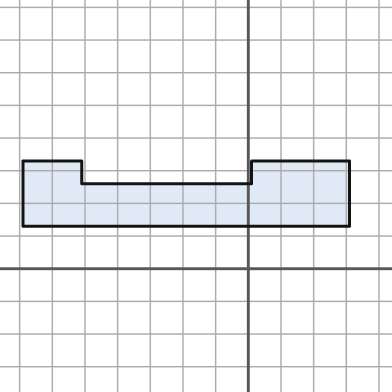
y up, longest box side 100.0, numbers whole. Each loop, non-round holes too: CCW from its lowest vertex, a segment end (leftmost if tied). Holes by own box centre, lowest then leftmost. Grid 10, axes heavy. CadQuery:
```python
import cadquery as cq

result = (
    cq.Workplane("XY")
    .moveTo(-69.0, 13.0)
    .lineTo(31.0, 13.0)
    .lineTo(31.0, 33.0)
    .lineTo(1.0, 33.0)
    .lineTo(1.0, 26.0)
    .lineTo(-51.0, 26.0)
    .lineTo(-51.0, 33.0)
    .lineTo(-69.0, 33.0)
    .close()
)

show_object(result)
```